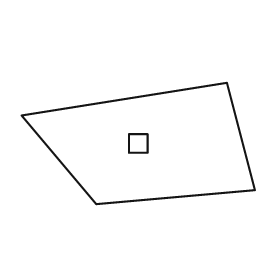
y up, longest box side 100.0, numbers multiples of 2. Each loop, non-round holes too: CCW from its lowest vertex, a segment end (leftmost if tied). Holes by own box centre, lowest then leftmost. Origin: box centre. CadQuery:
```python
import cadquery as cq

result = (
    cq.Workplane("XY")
    .moveTo(-18.0, -26.0)
    .lineTo(50.0, -20.0)
    .lineTo(38.0, 26.0)
    .lineTo(-50.0, 12.0)
    .close()
    .moveTo(-4.0, -4.0)
    .lineTo(4.0, -4.0)
    .lineTo(4.0, 4.0)
    .lineTo(-4.0, 4.0)
    .close()
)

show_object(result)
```